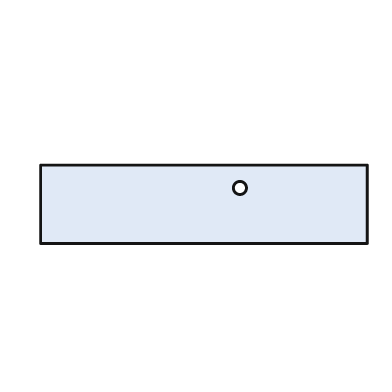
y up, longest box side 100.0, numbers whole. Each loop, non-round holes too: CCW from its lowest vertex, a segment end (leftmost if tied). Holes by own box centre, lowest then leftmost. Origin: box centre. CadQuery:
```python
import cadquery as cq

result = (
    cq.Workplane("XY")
    .moveTo(-50.0, -12.0)
    .lineTo(50.0, -12.0)
    .lineTo(50.0, 12.0)
    .lineTo(-50.0, 12.0)
    .close()
    .moveTo(11.0, 5.0)
    .circle(2.0)
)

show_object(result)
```